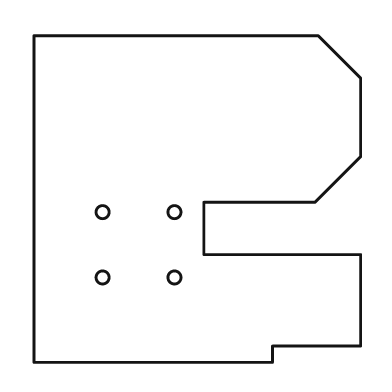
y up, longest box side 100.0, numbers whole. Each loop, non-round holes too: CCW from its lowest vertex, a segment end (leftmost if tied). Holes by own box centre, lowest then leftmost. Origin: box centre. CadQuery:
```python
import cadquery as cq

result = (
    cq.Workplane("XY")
    .moveTo(-50.0, -50.0)
    .lineTo(23.0, -50.0)
    .lineTo(23.0, -45.0)
    .lineTo(50.0, -45.0)
    .lineTo(50.0, -17.0)
    .lineTo(2.0, -17.0)
    .lineTo(2.0, -1.0)
    .lineTo(36.0, -1.0)
    .lineTo(50.0, 13.0)
    .lineTo(50.0, 37.0)
    .lineTo(37.0, 50.0)
    .lineTo(-50.0, 50.0)
    .close()
    .moveTo(-29.0, -24.0)
    .circle(2.0)
    .moveTo(-7.0, -24.0)
    .circle(2.0)
    .moveTo(-29.0, -4.0)
    .circle(2.0)
    .moveTo(-7.0, -4.0)
    .circle(2.0)
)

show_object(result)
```